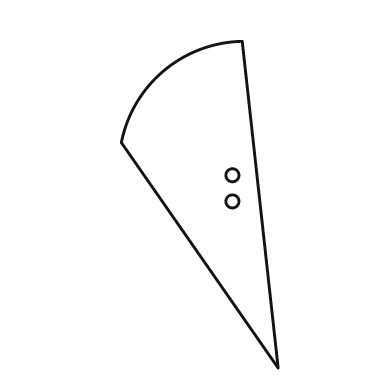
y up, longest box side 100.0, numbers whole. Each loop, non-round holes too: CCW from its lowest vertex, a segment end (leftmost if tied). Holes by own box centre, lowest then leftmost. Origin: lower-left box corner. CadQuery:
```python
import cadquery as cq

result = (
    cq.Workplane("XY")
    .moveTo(48.0, 0.0)
    .lineTo(37.0, 100.0)
    .threePointArc((13.0, 91.0), (0.0, 69.0))
    .close()
    .moveTo(34.0, 51.0)
    .circle(2.0)
    .moveTo(34.0, 59.0)
    .circle(2.0)
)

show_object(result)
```